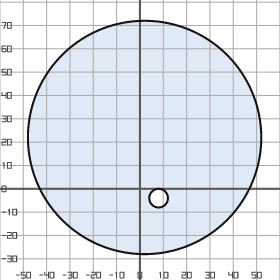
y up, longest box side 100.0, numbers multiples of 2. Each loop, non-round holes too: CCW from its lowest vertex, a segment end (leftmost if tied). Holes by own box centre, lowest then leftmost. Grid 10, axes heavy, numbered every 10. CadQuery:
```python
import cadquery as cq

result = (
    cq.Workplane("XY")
    .moveTo(2.0, 22.0)
    .circle(50.0)
    .moveTo(8.0, -4.0)
    .circle(4.0)
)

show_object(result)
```